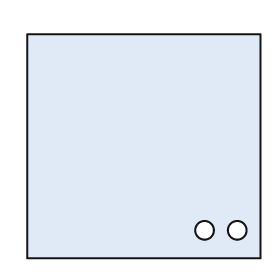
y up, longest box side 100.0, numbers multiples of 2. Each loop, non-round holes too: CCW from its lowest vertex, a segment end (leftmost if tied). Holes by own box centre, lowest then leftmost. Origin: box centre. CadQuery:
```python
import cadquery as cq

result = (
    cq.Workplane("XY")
    .moveTo(-50.0, -48.0)
    .lineTo(50.0, -48.0)
    .lineTo(50.0, 48.0)
    .lineTo(-50.0, 48.0)
    .close()
    .moveTo(26.0, -36.0)
    .circle(4.0)
    .moveTo(40.0, -36.0)
    .circle(4.0)
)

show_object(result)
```